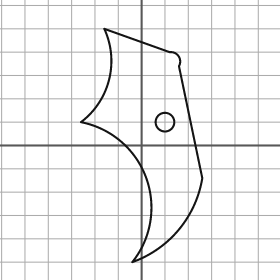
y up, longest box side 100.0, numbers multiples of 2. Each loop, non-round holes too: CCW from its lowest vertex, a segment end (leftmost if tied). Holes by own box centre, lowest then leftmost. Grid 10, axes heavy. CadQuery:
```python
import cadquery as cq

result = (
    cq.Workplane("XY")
    .moveTo(-4.0, -50.0)
    .threePointArc((16.0, -36.0), (26.0, -14.0))
    .lineTo(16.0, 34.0)
    .threePointArc((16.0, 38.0), (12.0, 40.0))
    .lineTo(-16.0, 50.0)
    .threePointArc((-14.0, 28.0), (-26.0, 10.0))
    .threePointArc((2.0, -14.0), (-4.0, -50.0))
    .close()
    .moveTo(10.0, 10.0)
    .circle(4.0)
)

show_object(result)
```